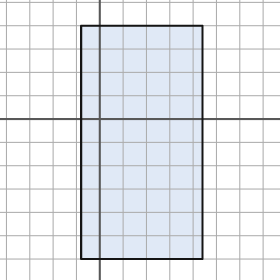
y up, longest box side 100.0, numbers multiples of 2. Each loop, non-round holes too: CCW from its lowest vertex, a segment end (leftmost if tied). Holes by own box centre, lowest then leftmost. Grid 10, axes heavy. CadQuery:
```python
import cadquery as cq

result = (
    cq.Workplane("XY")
    .moveTo(-8.0, -60.0)
    .lineTo(44.0, -60.0)
    .lineTo(44.0, 40.0)
    .lineTo(-8.0, 40.0)
    .close()
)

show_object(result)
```